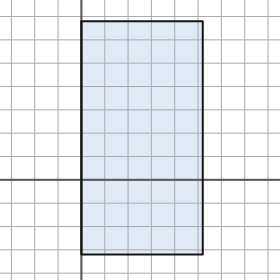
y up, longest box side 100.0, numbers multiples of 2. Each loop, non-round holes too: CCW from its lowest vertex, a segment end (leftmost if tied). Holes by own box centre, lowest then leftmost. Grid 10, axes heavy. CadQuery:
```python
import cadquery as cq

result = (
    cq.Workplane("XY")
    .moveTo(0.0, -32.0)
    .lineTo(52.0, -32.0)
    .lineTo(52.0, 68.0)
    .lineTo(0.0, 68.0)
    .close()
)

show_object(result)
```